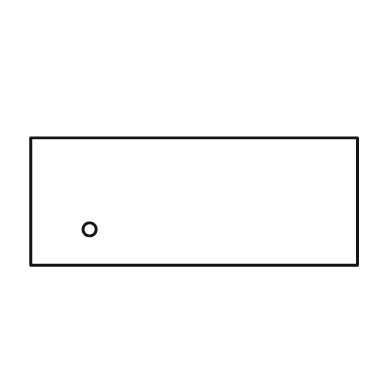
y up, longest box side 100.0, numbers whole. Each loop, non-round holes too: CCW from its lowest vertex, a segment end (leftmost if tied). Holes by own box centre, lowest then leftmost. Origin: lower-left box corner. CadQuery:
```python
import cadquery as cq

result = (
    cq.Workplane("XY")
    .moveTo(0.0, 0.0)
    .lineTo(100.0, 0.0)
    .lineTo(100.0, 39.0)
    .lineTo(0.0, 39.0)
    .close()
    .moveTo(18.0, 11.0)
    .circle(2.0)
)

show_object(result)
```